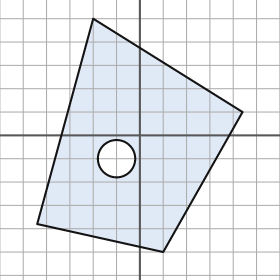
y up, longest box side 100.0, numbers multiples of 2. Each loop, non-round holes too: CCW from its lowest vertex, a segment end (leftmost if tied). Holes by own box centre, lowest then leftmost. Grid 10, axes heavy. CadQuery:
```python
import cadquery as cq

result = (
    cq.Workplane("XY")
    .moveTo(10.0, -50.0)
    .lineTo(44.0, 10.0)
    .lineTo(-20.0, 50.0)
    .lineTo(-44.0, -38.0)
    .close()
    .moveTo(-10.0, -10.0)
    .circle(8.0)
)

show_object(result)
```